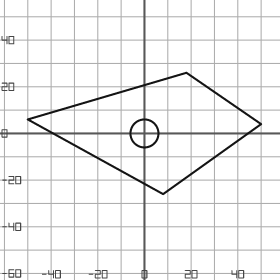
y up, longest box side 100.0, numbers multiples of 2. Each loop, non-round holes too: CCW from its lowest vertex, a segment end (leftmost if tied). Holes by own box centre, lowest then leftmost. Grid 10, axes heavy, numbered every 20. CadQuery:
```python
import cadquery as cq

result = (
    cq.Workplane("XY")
    .moveTo(8.0, -26.0)
    .lineTo(50.0, 4.0)
    .lineTo(18.0, 26.0)
    .lineTo(-50.0, 6.0)
    .close()
    .moveTo(0.0, 0.0)
    .circle(6.0)
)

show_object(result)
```